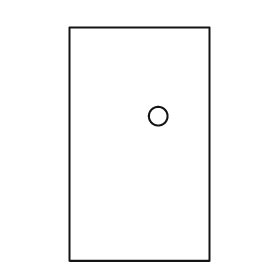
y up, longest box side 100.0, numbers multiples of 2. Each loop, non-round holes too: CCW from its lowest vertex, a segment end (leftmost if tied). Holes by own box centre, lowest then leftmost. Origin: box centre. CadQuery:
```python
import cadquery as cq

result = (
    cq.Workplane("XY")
    .moveTo(-30.0, -50.0)
    .lineTo(30.0, -50.0)
    .lineTo(30.0, 50.0)
    .lineTo(-30.0, 50.0)
    .close()
    .moveTo(8.0, 12.0)
    .circle(4.0)
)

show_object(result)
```